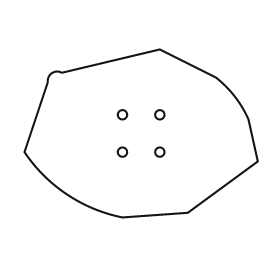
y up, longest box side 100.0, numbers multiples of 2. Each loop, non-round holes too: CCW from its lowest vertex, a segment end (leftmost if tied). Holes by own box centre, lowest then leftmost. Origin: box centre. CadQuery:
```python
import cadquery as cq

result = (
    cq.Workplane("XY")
    .moveTo(-8.0, -36.0)
    .lineTo(20.0, -34.0)
    .lineTo(50.0, -12.0)
    .lineTo(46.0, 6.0)
    .threePointArc((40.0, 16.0), (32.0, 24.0))
    .lineTo(8.0, 36.0)
    .lineTo(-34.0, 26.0)
    .threePointArc((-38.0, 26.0), (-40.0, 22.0))
    .lineTo(-50.0, -8.0)
    .threePointArc((-32.0, -26.0), (-8.0, -36.0))
    .close()
    .moveTo(-8.0, -8.0)
    .circle(2.0)
    .moveTo(8.0, -8.0)
    .circle(2.0)
    .moveTo(-8.0, 8.0)
    .circle(2.0)
    .moveTo(8.0, 8.0)
    .circle(2.0)
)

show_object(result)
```